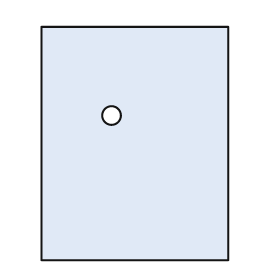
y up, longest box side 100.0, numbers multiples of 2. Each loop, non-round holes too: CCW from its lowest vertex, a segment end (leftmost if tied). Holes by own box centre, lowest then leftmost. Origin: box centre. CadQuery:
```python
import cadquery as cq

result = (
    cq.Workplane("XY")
    .moveTo(-40.0, -50.0)
    .lineTo(40.0, -50.0)
    .lineTo(40.0, 50.0)
    .lineTo(-40.0, 50.0)
    .close()
    .moveTo(-10.0, 12.0)
    .circle(4.0)
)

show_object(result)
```